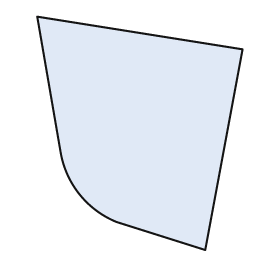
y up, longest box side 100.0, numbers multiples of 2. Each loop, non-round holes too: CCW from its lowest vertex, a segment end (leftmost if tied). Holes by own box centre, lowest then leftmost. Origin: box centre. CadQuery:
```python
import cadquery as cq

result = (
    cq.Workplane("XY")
    .moveTo(28.0, -50.0)
    .lineTo(44.0, 36.0)
    .lineTo(-44.0, 50.0)
    .lineTo(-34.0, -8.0)
    .threePointArc((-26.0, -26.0), (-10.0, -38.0))
    .close()
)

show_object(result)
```